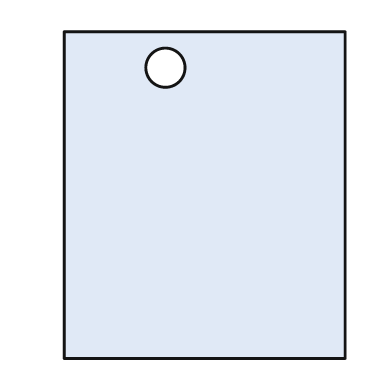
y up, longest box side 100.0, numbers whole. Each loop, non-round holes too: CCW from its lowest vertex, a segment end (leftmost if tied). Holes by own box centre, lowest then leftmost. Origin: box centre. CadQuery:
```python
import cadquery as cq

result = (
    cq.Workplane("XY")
    .moveTo(-43.0, -50.0)
    .lineTo(43.0, -50.0)
    .lineTo(43.0, 50.0)
    .lineTo(-43.0, 50.0)
    .close()
    .moveTo(-12.0, 39.0)
    .circle(6.0)
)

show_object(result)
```